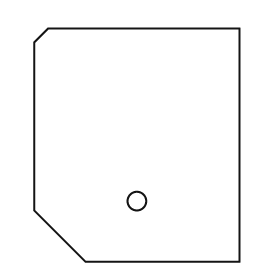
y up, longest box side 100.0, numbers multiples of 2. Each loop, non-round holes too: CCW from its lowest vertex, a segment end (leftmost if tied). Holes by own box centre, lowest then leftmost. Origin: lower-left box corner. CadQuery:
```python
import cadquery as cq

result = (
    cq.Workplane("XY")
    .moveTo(22.0, 0.0)
    .lineTo(88.0, 0.0)
    .lineTo(88.0, 100.0)
    .lineTo(6.0, 100.0)
    .lineTo(0.0, 94.0)
    .lineTo(0.0, 22.0)
    .close()
    .moveTo(44.0, 26.0)
    .circle(4.0)
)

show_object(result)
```